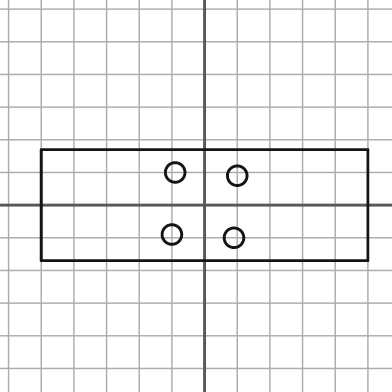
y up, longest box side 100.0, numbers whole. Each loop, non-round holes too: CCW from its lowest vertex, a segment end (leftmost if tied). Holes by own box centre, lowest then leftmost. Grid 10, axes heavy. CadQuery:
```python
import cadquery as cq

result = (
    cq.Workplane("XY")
    .moveTo(-50.0, -17.0)
    .lineTo(50.0, -17.0)
    .lineTo(50.0, 17.0)
    .lineTo(-50.0, 17.0)
    .close()
    .moveTo(9.0, -10.0)
    .circle(3.0)
    .moveTo(-10.0, -9.0)
    .circle(3.0)
    .moveTo(10.0, 9.0)
    .circle(3.0)
    .moveTo(-9.0, 10.0)
    .circle(3.0)
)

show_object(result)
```